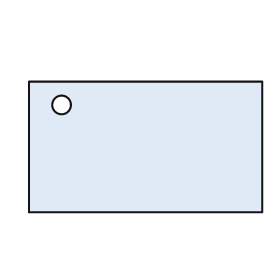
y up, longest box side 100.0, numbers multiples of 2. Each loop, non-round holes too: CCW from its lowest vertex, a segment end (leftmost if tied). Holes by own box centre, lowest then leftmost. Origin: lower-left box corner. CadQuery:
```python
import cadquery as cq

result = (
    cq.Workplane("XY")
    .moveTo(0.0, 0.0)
    .lineTo(100.0, 0.0)
    .lineTo(100.0, 56.0)
    .lineTo(0.0, 56.0)
    .close()
    .moveTo(14.0, 46.0)
    .circle(4.0)
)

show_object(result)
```